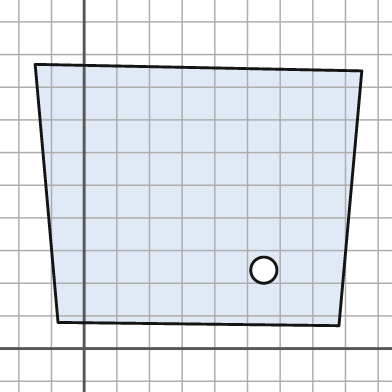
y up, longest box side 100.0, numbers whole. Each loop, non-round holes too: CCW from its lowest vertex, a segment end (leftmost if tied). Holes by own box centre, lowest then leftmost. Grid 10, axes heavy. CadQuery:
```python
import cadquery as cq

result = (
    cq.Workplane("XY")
    .moveTo(78.0, 7.0)
    .lineTo(85.0, 85.0)
    .lineTo(-15.0, 87.0)
    .lineTo(-8.0, 8.0)
    .close()
    .moveTo(55.0, 24.0)
    .circle(4.0)
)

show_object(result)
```